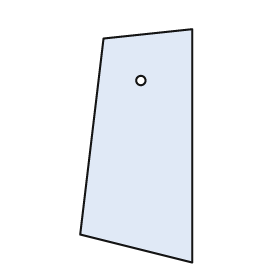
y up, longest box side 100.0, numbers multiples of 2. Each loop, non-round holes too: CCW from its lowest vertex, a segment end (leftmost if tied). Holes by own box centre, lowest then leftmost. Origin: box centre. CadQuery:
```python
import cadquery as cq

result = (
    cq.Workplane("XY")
    .moveTo(24.0, -50.0)
    .lineTo(24.0, 50.0)
    .lineTo(-14.0, 46.0)
    .lineTo(-24.0, -38.0)
    .close()
    .moveTo(2.0, 28.0)
    .circle(2.0)
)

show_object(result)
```